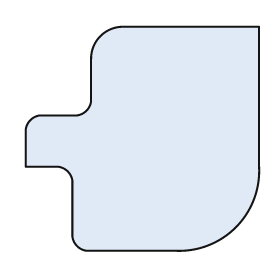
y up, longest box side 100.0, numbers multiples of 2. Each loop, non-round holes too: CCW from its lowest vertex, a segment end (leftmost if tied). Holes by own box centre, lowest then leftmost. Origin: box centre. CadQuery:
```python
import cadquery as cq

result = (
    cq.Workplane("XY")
    .moveTo(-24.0, -48.0)
    .lineTo(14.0, -48.0)
    .threePointArc((40.0, -38.0), (50.0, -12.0))
    .lineTo(50.0, 48.0)
    .lineTo(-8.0, 48.0)
    .threePointArc((-18.0, 44.0), (-22.0, 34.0))
    .lineTo(-22.0, 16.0)
    .threePointArc((-24.0, 12.0), (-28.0, 10.0))
    .lineTo(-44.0, 10.0)
    .threePointArc((-48.0, 8.0), (-50.0, 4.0))
    .lineTo(-50.0, -12.0)
    .lineTo(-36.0, -12.0)
    .threePointArc((-32.0, -14.0), (-30.0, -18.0))
    .lineTo(-30.0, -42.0)
    .threePointArc((-28.0, -46.0), (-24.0, -48.0))
    .close()
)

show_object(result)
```